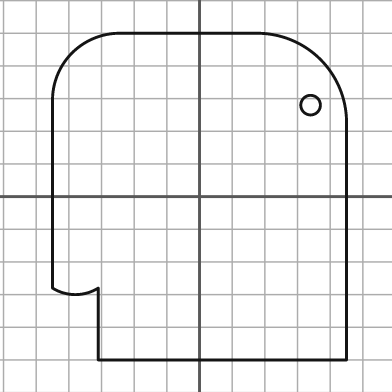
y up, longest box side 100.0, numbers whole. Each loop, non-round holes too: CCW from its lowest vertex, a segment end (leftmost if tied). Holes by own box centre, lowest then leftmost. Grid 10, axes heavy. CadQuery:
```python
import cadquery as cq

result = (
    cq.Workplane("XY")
    .moveTo(-31.0, -50.0)
    .lineTo(45.0, -50.0)
    .lineTo(45.0, 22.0)
    .threePointArc((37.0, 42.0), (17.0, 50.0))
    .lineTo(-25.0, 50.0)
    .threePointArc((-39.0, 44.0), (-45.0, 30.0))
    .lineTo(-45.0, -28.0)
    .threePointArc((-38.0, -30.0), (-31.0, -28.0))
    .close()
    .moveTo(34.0, 28.0)
    .circle(3.0)
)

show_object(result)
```